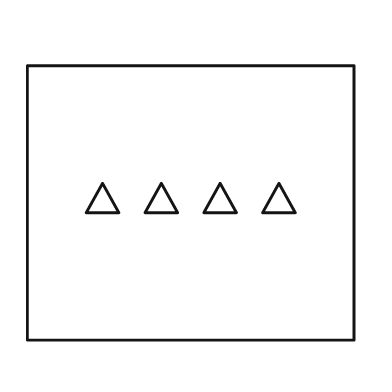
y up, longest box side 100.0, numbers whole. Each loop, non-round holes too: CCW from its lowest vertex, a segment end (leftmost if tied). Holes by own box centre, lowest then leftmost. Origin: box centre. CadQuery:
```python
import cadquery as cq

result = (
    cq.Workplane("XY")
    .moveTo(-50.0, -42.0)
    .lineTo(50.0, -42.0)
    .lineTo(50.0, 42.0)
    .lineTo(-50.0, 42.0)
    .close()
    .moveTo(-32.0, -3.0)
    .lineTo(-22.0, -3.0)
    .lineTo(-27.0, 6.0)
    .close()
    .moveTo(-14.0, -3.0)
    .lineTo(-4.0, -3.0)
    .lineTo(-9.0, 6.0)
    .close()
    .moveTo(4.0, -3.0)
    .lineTo(14.0, -3.0)
    .lineTo(9.0, 6.0)
    .close()
    .moveTo(22.0, -3.0)
    .lineTo(32.0, -3.0)
    .lineTo(27.0, 6.0)
    .close()
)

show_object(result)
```